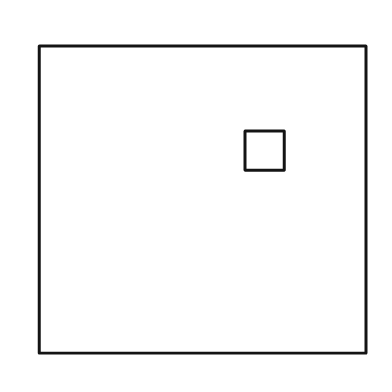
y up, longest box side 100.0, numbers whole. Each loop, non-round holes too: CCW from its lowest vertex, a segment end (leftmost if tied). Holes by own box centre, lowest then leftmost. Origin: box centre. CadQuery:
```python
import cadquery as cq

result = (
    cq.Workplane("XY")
    .moveTo(-50.0, -47.0)
    .lineTo(50.0, -47.0)
    .lineTo(50.0, 47.0)
    .lineTo(-50.0, 47.0)
    .close()
    .moveTo(13.0, 9.0)
    .lineTo(25.0, 9.0)
    .lineTo(25.0, 21.0)
    .lineTo(13.0, 21.0)
    .close()
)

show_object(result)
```